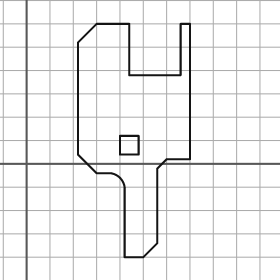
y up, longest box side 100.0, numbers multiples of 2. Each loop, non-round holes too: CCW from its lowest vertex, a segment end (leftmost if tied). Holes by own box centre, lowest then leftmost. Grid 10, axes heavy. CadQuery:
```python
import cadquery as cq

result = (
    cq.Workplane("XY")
    .moveTo(42.0, -40.0)
    .lineTo(50.0, -40.0)
    .lineTo(56.0, -34.0)
    .lineTo(56.0, -2.0)
    .lineTo(60.0, 2.0)
    .lineTo(70.0, 2.0)
    .lineTo(70.0, 60.0)
    .lineTo(66.0, 60.0)
    .lineTo(66.0, 38.0)
    .lineTo(44.0, 38.0)
    .lineTo(44.0, 60.0)
    .lineTo(30.0, 60.0)
    .lineTo(22.0, 52.0)
    .lineTo(22.0, 4.0)
    .lineTo(30.0, -4.0)
    .lineTo(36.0, -4.0)
    .threePointArc((40.0, -6.0), (42.0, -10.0))
    .close()
    .moveTo(40.0, 4.0)
    .lineTo(48.0, 4.0)
    .lineTo(48.0, 12.0)
    .lineTo(40.0, 12.0)
    .close()
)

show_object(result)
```